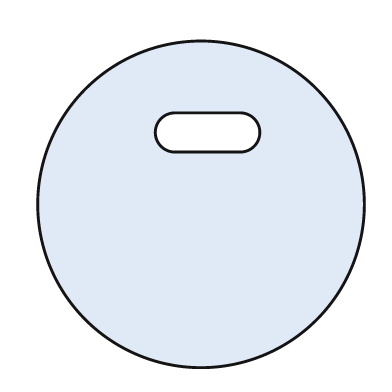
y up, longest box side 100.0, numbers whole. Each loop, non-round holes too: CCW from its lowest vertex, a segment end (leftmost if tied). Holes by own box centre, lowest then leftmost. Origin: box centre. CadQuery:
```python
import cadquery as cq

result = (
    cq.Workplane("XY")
    .moveTo(0.0, 0.0)
    .circle(50.0)
    .moveTo(-8.0, 16.0)
    .lineTo(12.0, 16.0)
    .threePointArc((18.0, 22.0), (12.0, 28.0))
    .lineTo(-8.0, 28.0)
    .threePointArc((-14.0, 22.0), (-8.0, 16.0))
    .close()
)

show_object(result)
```